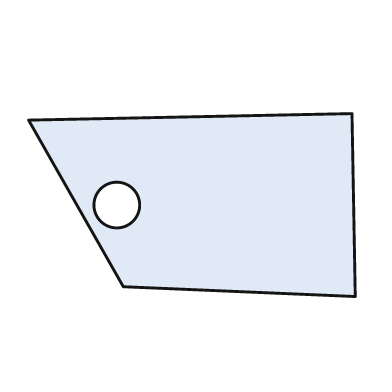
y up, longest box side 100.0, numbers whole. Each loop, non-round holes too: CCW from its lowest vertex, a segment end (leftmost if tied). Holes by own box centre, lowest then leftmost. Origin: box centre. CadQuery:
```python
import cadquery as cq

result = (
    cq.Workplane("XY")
    .moveTo(50.0, -28.0)
    .lineTo(49.0, 28.0)
    .lineTo(-50.0, 26.0)
    .lineTo(-21.0, -25.0)
    .close()
    .moveTo(-23.0, 0.0)
    .circle(7.0)
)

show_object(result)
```